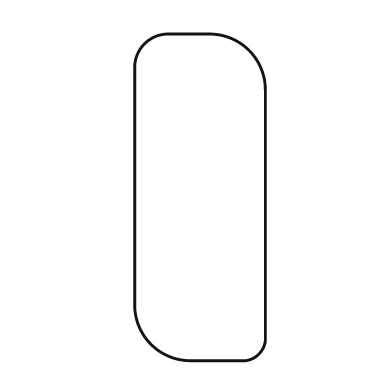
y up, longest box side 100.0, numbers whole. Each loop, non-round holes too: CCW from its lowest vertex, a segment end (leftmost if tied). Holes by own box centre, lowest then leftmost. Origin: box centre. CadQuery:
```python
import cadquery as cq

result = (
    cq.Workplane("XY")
    .moveTo(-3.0, -50.0)
    .lineTo(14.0, -50.0)
    .threePointArc((18.0, -48.0), (20.0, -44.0))
    .lineTo(20.0, 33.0)
    .threePointArc((15.0, 45.0), (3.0, 50.0))
    .lineTo(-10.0, 50.0)
    .threePointArc((-17.0, 47.0), (-20.0, 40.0))
    .lineTo(-20.0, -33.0)
    .threePointArc((-15.0, -45.0), (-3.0, -50.0))
    .close()
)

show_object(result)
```